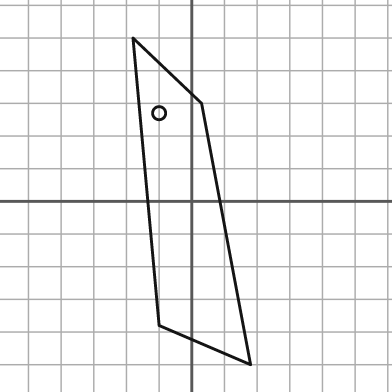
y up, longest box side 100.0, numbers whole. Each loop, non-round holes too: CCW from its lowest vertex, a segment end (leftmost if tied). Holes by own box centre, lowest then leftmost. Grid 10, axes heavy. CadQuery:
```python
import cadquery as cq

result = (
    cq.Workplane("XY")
    .moveTo(18.0, -50.0)
    .lineTo(3.0, 30.0)
    .lineTo(-18.0, 50.0)
    .lineTo(-10.0, -38.0)
    .close()
    .moveTo(-10.0, 27.0)
    .circle(2.0)
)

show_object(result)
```